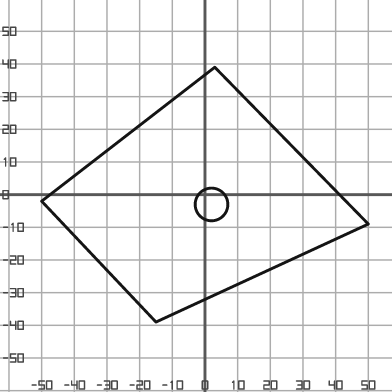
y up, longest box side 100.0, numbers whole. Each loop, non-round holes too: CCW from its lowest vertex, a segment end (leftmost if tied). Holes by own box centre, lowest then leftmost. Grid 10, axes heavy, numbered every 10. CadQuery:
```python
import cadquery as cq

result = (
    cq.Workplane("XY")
    .moveTo(-15.0, -39.0)
    .lineTo(50.0, -9.0)
    .lineTo(3.0, 39.0)
    .lineTo(-50.0, -2.0)
    .close()
    .moveTo(2.0, -3.0)
    .circle(5.0)
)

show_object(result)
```